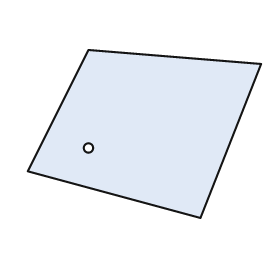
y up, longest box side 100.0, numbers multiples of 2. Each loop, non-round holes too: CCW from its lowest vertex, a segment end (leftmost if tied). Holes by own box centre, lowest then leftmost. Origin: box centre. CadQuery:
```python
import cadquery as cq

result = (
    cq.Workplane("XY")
    .moveTo(24.0, -36.0)
    .lineTo(50.0, 30.0)
    .lineTo(-24.0, 36.0)
    .lineTo(-50.0, -16.0)
    .close()
    .moveTo(-24.0, -6.0)
    .circle(2.0)
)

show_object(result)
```